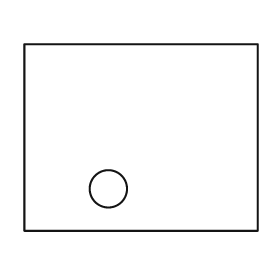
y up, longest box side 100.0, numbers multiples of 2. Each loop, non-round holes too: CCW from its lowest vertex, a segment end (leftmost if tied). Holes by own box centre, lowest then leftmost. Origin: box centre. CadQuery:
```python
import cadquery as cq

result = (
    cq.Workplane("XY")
    .moveTo(-50.0, -40.0)
    .lineTo(50.0, -40.0)
    .lineTo(50.0, 40.0)
    .lineTo(-50.0, 40.0)
    .close()
    .moveTo(-14.0, -22.0)
    .circle(8.0)
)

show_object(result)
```